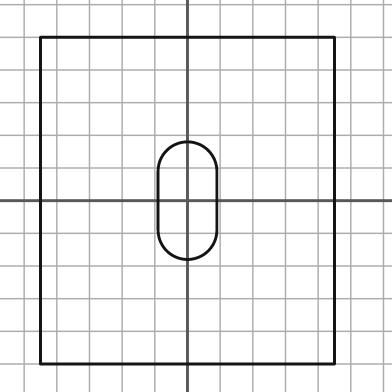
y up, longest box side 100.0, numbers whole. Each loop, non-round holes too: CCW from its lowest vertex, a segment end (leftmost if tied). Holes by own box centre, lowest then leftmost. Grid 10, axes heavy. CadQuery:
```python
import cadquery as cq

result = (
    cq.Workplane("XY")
    .moveTo(-45.0, -50.0)
    .lineTo(45.0, -50.0)
    .lineTo(45.0, 50.0)
    .lineTo(-45.0, 50.0)
    .close()
    .moveTo(-9.0, -9.0)
    .threePointArc((0.0, -18.0), (9.0, -9.0))
    .lineTo(9.0, 9.0)
    .threePointArc((0.0, 18.0), (-9.0, 9.0))
    .close()
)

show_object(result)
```